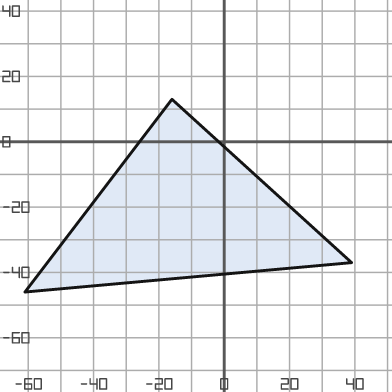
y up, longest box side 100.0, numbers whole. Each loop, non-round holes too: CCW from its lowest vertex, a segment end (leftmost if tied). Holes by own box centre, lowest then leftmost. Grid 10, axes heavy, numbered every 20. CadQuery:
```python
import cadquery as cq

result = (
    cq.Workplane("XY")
    .moveTo(-61.0, -46.0)
    .lineTo(39.0, -37.0)
    .lineTo(-16.0, 13.0)
    .close()
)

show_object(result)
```